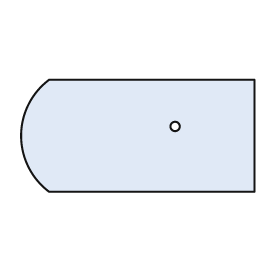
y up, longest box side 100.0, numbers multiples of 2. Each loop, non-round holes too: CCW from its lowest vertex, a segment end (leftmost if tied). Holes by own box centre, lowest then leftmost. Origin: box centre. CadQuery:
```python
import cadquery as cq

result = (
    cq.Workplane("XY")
    .moveTo(-38.0, -24.0)
    .lineTo(50.0, -24.0)
    .lineTo(50.0, 24.0)
    .lineTo(-38.0, 24.0)
    .threePointArc((-50.0, 0.0), (-38.0, -24.0))
    .close()
    .moveTo(16.0, 4.0)
    .circle(2.0)
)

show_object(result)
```